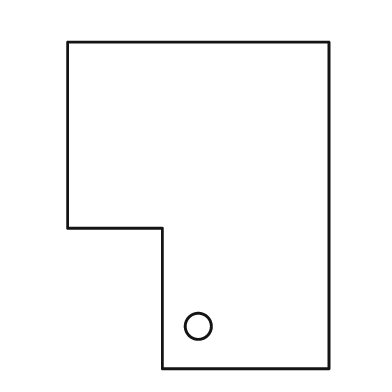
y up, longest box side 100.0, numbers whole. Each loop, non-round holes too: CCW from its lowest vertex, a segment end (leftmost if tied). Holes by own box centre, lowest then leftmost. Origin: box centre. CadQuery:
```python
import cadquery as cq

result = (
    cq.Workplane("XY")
    .moveTo(-11.0, -50.0)
    .lineTo(40.0, -50.0)
    .lineTo(40.0, 50.0)
    .lineTo(-40.0, 50.0)
    .lineTo(-40.0, -7.0)
    .lineTo(-11.0, -7.0)
    .close()
    .moveTo(0.0, -37.0)
    .circle(4.0)
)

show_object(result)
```